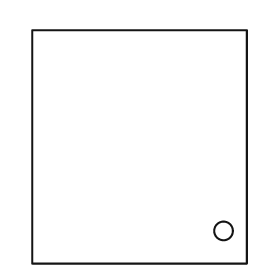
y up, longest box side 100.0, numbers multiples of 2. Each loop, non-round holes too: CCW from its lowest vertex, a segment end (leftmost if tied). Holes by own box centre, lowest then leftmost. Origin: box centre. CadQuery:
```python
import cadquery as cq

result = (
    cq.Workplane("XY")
    .moveTo(-46.0, -50.0)
    .lineTo(46.0, -50.0)
    .lineTo(46.0, 50.0)
    .lineTo(-46.0, 50.0)
    .close()
    .moveTo(36.0, -36.0)
    .circle(4.0)
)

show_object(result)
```